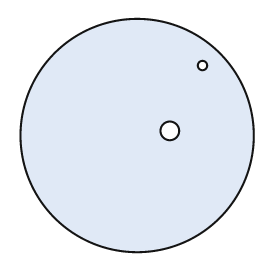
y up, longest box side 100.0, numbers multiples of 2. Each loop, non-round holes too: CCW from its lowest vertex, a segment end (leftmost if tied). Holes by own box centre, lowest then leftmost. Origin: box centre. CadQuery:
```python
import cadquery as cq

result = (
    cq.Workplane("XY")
    .moveTo(0.0, 0.0)
    .circle(50.0)
    .moveTo(14.0, 2.0)
    .circle(4.0)
    .moveTo(28.0, 30.0)
    .circle(2.0)
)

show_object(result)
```